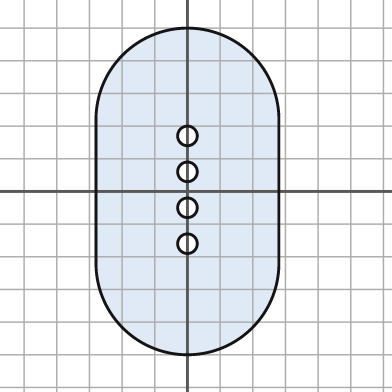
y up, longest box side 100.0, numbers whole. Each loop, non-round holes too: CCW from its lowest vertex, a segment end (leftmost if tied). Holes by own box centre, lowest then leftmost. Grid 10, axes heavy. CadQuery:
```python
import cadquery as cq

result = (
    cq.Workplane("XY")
    .moveTo(-28.0, -22.0)
    .threePointArc((0.0, -50.0), (28.0, -22.0))
    .lineTo(28.0, 22.0)
    .threePointArc((0.0, 50.0), (-28.0, 22.0))
    .close()
    .moveTo(0.0, -16.0)
    .circle(3.0)
    .moveTo(0.0, -5.0)
    .circle(3.0)
    .moveTo(0.0, 6.0)
    .circle(3.0)
    .moveTo(0.0, 17.0)
    .circle(3.0)
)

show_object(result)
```